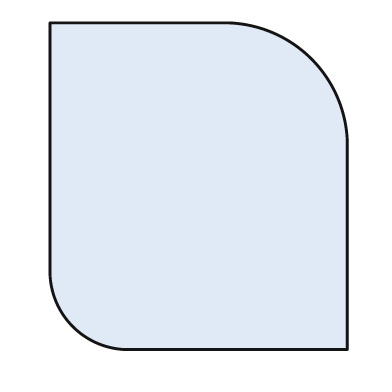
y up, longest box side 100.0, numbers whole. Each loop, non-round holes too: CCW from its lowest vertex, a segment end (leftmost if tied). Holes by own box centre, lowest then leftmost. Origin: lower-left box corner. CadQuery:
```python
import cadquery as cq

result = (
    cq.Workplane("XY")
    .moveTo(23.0, 0.0)
    .lineTo(91.0, 0.0)
    .lineTo(91.0, 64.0)
    .threePointArc((80.0, 89.0), (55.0, 100.0))
    .lineTo(0.0, 100.0)
    .lineTo(0.0, 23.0)
    .threePointArc((7.0, 7.0), (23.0, 0.0))
    .close()
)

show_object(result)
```